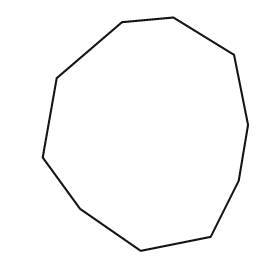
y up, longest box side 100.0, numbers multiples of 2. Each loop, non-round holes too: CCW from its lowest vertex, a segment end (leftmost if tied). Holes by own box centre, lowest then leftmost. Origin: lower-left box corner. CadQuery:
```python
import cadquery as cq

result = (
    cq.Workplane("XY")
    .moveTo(42.0, 0.0)
    .lineTo(72.0, 6.0)
    .lineTo(84.0, 30.0)
    .lineTo(88.0, 54.0)
    .lineTo(82.0, 84.0)
    .lineTo(56.0, 100.0)
    .lineTo(34.0, 98.0)
    .lineTo(6.0, 74.0)
    .lineTo(0.0, 40.0)
    .lineTo(16.0, 18.0)
    .close()
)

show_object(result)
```